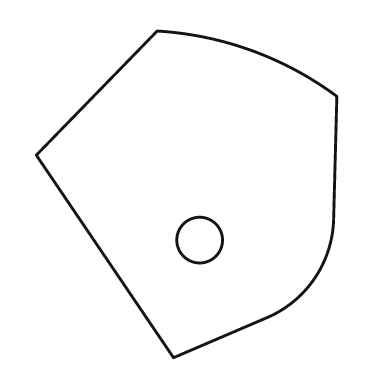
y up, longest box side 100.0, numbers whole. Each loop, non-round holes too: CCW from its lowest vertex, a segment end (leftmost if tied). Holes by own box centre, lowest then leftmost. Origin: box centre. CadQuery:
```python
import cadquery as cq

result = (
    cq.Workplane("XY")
    .moveTo(-4.0, -50.0)
    .lineTo(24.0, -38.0)
    .threePointArc((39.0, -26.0), (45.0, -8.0))
    .lineTo(46.0, 30.0)
    .threePointArc((20.0, 44.0), (-9.0, 50.0))
    .lineTo(-46.0, 12.0)
    .close()
    .moveTo(4.0, -14.0)
    .circle(7.0)
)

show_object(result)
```